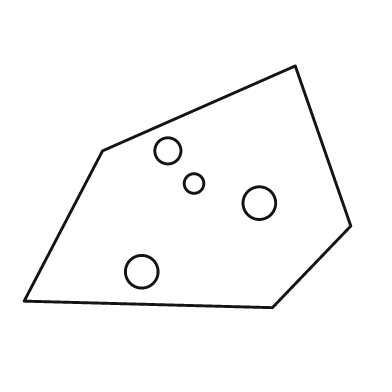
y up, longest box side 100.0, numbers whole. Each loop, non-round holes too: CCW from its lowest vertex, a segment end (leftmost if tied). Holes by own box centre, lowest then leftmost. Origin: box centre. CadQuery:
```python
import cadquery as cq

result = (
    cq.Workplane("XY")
    .moveTo(26.0, -37.0)
    .lineTo(50.0, -12.0)
    .lineTo(33.0, 37.0)
    .lineTo(-26.0, 11.0)
    .lineTo(-50.0, -35.0)
    .close()
    .moveTo(-14.0, -26.0)
    .circle(5.0)
    .moveTo(22.0, -5.0)
    .circle(5.0)
    .moveTo(2.0, 1.0)
    .circle(3.0)
    .moveTo(-6.0, 11.0)
    .circle(4.0)
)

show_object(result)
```